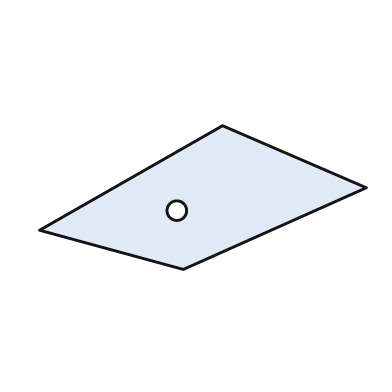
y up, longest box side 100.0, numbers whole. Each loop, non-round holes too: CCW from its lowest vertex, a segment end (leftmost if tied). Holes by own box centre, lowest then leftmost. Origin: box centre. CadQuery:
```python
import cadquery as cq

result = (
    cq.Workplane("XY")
    .moveTo(-6.0, -22.0)
    .lineTo(50.0, 3.0)
    .lineTo(6.0, 22.0)
    .lineTo(-50.0, -10.0)
    .close()
    .moveTo(-8.0, -4.0)
    .circle(3.0)
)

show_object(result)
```